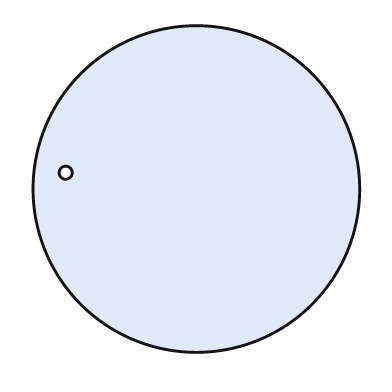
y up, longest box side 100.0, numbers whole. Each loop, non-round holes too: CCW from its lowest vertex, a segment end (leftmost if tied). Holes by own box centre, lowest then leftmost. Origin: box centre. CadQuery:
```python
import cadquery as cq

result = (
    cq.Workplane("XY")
    .moveTo(0.0, 0.0)
    .circle(50.0)
    .moveTo(-40.0, 5.0)
    .circle(2.0)
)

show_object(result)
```